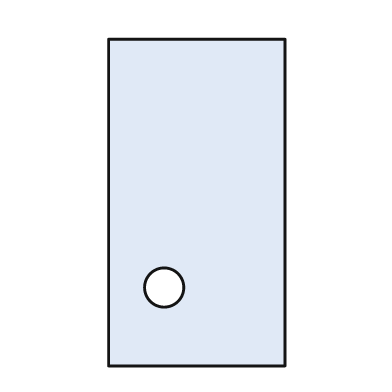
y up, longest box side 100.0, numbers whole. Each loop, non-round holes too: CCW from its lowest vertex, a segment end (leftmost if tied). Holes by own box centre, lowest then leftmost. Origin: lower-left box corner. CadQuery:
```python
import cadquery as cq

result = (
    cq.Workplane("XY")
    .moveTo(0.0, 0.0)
    .lineTo(54.0, 0.0)
    .lineTo(54.0, 100.0)
    .lineTo(0.0, 100.0)
    .close()
    .moveTo(17.0, 24.0)
    .circle(6.0)
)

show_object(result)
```